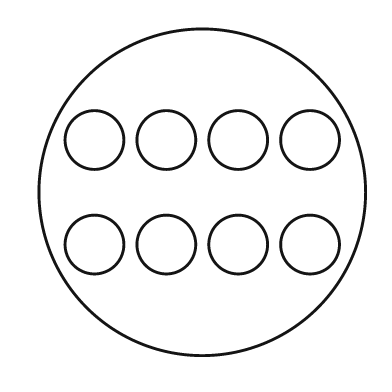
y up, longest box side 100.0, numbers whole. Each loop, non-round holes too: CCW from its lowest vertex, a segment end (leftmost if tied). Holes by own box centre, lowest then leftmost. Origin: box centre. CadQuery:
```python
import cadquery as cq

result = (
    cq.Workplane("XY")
    .moveTo(0.0, 0.0)
    .circle(50.0)
    .moveTo(-33.0, -16.0)
    .circle(9.0)
    .moveTo(-11.0, -16.0)
    .circle(9.0)
    .moveTo(11.0, -16.0)
    .circle(9.0)
    .moveTo(33.0, -16.0)
    .circle(9.0)
    .moveTo(-33.0, 16.0)
    .circle(9.0)
    .moveTo(-11.0, 16.0)
    .circle(9.0)
    .moveTo(11.0, 16.0)
    .circle(9.0)
    .moveTo(33.0, 16.0)
    .circle(9.0)
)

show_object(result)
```